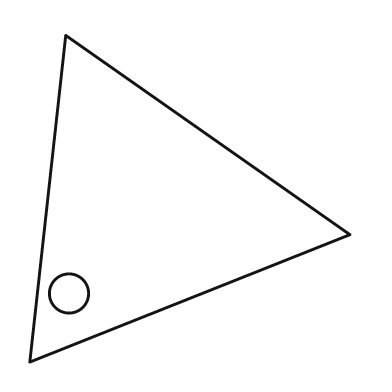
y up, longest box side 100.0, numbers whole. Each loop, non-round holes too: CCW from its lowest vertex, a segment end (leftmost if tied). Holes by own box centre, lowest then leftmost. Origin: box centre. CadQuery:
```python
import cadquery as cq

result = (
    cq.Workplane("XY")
    .moveTo(-49.0, -50.0)
    .lineTo(49.0, -11.0)
    .lineTo(-38.0, 50.0)
    .close()
    .moveTo(-37.0, -29.0)
    .circle(6.0)
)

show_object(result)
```